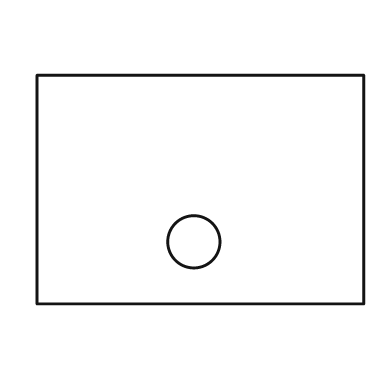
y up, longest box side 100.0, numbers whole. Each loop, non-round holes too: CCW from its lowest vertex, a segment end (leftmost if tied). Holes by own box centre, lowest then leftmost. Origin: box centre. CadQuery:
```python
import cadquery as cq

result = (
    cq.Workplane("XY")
    .moveTo(-50.0, -35.0)
    .lineTo(50.0, -35.0)
    .lineTo(50.0, 35.0)
    .lineTo(-50.0, 35.0)
    .close()
    .moveTo(-2.0, -16.0)
    .circle(8.0)
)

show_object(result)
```